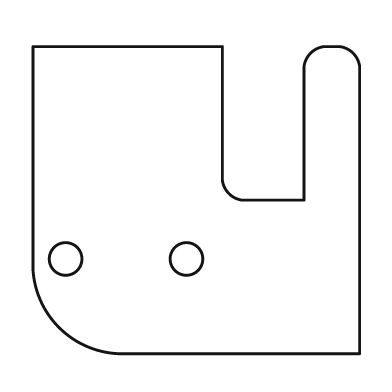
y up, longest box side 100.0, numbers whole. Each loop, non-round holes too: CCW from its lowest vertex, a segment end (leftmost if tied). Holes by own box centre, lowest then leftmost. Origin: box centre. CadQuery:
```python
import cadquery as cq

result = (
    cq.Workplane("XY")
    .moveTo(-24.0, -47.0)
    .lineTo(50.0, -47.0)
    .lineTo(50.0, 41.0)
    .threePointArc((48.0, 45.0), (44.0, 47.0))
    .lineTo(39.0, 47.0)
    .threePointArc((35.0, 45.0), (33.0, 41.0))
    .lineTo(33.0, 0.0)
    .lineTo(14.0, 0.0)
    .threePointArc((10.0, 2.0), (8.0, 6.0))
    .lineTo(8.0, 47.0)
    .lineTo(-50.0, 47.0)
    .lineTo(-50.0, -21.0)
    .threePointArc((-42.0, -39.0), (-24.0, -47.0))
    .close()
    .moveTo(-40.0, -18.0)
    .circle(5.0)
    .moveTo(-3.0, -18.0)
    .circle(5.0)
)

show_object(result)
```